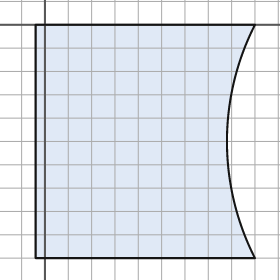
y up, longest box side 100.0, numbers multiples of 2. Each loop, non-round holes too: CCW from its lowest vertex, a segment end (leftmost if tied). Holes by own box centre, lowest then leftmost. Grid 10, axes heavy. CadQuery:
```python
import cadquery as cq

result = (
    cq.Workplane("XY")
    .moveTo(-4.0, -100.0)
    .lineTo(90.0, -100.0)
    .threePointArc((78.0, -50.0), (90.0, 0.0))
    .lineTo(-4.0, 0.0)
    .close()
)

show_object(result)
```